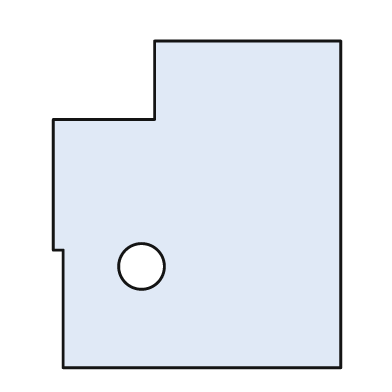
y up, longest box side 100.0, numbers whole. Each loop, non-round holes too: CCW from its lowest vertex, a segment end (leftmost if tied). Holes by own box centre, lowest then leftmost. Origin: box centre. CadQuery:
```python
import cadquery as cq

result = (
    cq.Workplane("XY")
    .moveTo(-41.0, -50.0)
    .lineTo(44.0, -50.0)
    .lineTo(44.0, 50.0)
    .lineTo(-13.0, 50.0)
    .lineTo(-13.0, 26.0)
    .lineTo(-44.0, 26.0)
    .lineTo(-44.0, -14.0)
    .lineTo(-41.0, -14.0)
    .close()
    .moveTo(-17.0, -19.0)
    .circle(7.0)
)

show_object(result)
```